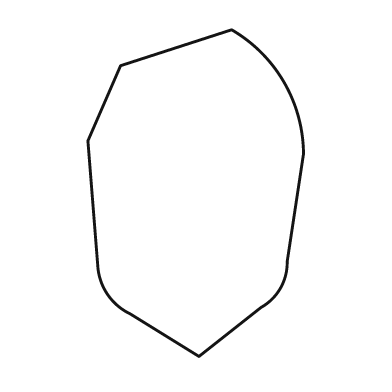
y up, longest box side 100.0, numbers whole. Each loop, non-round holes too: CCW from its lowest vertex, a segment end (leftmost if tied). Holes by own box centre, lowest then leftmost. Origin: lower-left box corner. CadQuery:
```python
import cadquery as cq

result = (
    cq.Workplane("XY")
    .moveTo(34.0, 0.0)
    .lineTo(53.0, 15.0)
    .threePointArc((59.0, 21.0), (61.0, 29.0))
    .lineTo(66.0, 62.0)
    .threePointArc((60.0, 84.0), (44.0, 100.0))
    .lineTo(10.0, 89.0)
    .lineTo(0.0, 66.0)
    .lineTo(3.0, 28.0)
    .threePointArc((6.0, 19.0), (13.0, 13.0))
    .close()
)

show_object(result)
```